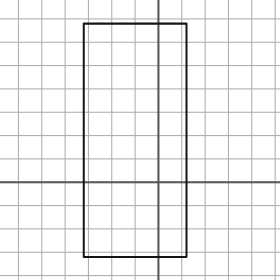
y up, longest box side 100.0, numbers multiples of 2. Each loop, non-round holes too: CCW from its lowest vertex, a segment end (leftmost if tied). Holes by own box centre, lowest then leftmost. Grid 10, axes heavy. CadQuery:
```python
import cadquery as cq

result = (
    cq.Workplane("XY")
    .moveTo(-32.0, -32.0)
    .lineTo(12.0, -32.0)
    .lineTo(12.0, 68.0)
    .lineTo(-32.0, 68.0)
    .close()
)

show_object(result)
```